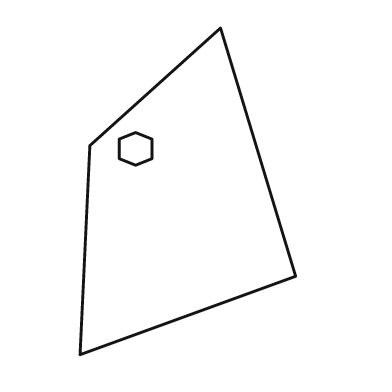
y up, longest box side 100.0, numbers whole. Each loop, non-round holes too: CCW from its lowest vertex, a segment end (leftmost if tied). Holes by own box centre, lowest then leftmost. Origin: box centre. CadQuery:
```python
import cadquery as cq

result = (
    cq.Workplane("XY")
    .moveTo(-33.0, -50.0)
    .lineTo(33.0, -26.0)
    .lineTo(10.0, 50.0)
    .lineTo(-30.0, 14.0)
    .close()
    .moveTo(-16.0, 8.0)
    .lineTo(-11.0, 10.0)
    .lineTo(-11.0, 16.0)
    .lineTo(-16.0, 18.0)
    .lineTo(-21.0, 16.0)
    .lineTo(-21.0, 10.0)
    .close()
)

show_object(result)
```